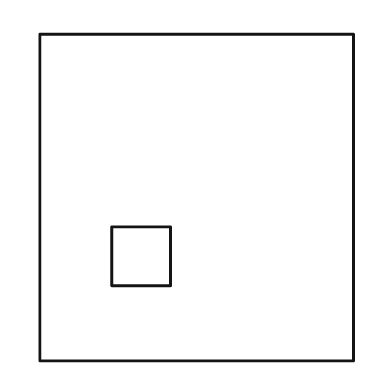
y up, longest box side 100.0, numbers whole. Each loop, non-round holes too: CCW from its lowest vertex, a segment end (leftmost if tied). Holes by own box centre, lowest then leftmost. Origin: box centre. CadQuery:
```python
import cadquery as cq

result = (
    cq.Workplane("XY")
    .moveTo(-48.0, -50.0)
    .lineTo(48.0, -50.0)
    .lineTo(48.0, 50.0)
    .lineTo(-48.0, 50.0)
    .close()
    .moveTo(-26.0, -27.0)
    .lineTo(-8.0, -27.0)
    .lineTo(-8.0, -9.0)
    .lineTo(-26.0, -9.0)
    .close()
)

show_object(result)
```